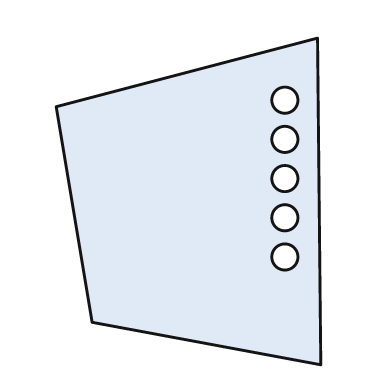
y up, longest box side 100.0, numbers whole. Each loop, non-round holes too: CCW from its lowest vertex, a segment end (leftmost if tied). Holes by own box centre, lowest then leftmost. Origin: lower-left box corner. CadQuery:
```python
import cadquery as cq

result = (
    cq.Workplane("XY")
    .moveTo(81.0, 0.0)
    .lineTo(80.0, 100.0)
    .lineTo(0.0, 79.0)
    .lineTo(11.0, 13.0)
    .close()
    .moveTo(70.0, 33.0)
    .circle(4.0)
    .moveTo(70.0, 45.0)
    .circle(4.0)
    .moveTo(70.0, 57.0)
    .circle(4.0)
    .moveTo(70.0, 69.0)
    .circle(4.0)
    .moveTo(70.0, 81.0)
    .circle(4.0)
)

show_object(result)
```